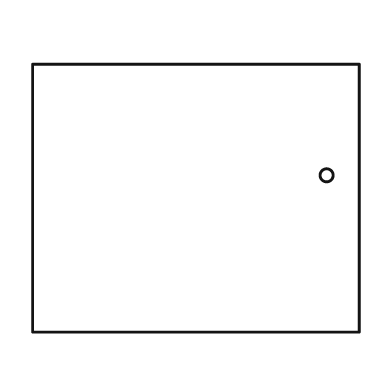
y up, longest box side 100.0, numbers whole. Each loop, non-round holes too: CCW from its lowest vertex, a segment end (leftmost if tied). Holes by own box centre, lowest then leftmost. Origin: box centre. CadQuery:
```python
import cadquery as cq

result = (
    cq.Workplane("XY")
    .moveTo(-50.0, -41.0)
    .lineTo(50.0, -41.0)
    .lineTo(50.0, 41.0)
    .lineTo(-50.0, 41.0)
    .close()
    .moveTo(40.0, 7.0)
    .circle(2.0)
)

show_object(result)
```